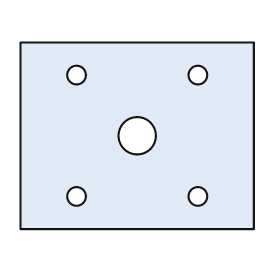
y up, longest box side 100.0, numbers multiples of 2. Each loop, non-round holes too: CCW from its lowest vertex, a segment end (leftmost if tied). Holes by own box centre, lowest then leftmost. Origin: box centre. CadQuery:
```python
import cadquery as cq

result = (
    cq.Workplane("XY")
    .moveTo(-50.0, -40.0)
    .lineTo(50.0, -40.0)
    .lineTo(50.0, 40.0)
    .lineTo(-50.0, 40.0)
    .close()
    .moveTo(-26.0, -26.0)
    .circle(4.0)
    .moveTo(26.0, -26.0)
    .circle(4.0)
    .moveTo(0.0, 0.0)
    .circle(8.0)
    .moveTo(-26.0, 26.0)
    .circle(4.0)
    .moveTo(26.0, 26.0)
    .circle(4.0)
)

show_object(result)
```